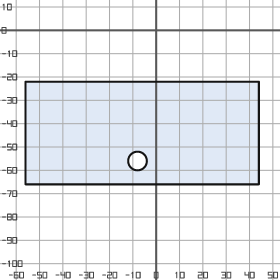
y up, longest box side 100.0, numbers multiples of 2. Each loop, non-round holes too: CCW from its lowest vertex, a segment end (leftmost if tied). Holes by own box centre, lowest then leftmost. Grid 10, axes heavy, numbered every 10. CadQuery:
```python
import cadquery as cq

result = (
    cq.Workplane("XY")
    .moveTo(-56.0, -66.0)
    .lineTo(44.0, -66.0)
    .lineTo(44.0, -22.0)
    .lineTo(-56.0, -22.0)
    .close()
    .moveTo(-8.0, -56.0)
    .circle(4.0)
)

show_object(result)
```